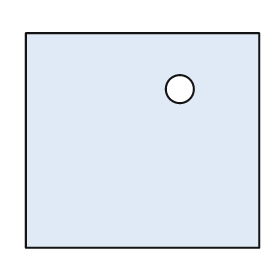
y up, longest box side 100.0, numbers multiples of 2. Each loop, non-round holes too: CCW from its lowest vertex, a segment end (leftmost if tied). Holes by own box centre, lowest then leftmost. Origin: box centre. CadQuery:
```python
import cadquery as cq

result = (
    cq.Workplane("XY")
    .moveTo(-50.0, -46.0)
    .lineTo(50.0, -46.0)
    .lineTo(50.0, 46.0)
    .lineTo(-50.0, 46.0)
    .close()
    .moveTo(16.0, 22.0)
    .circle(6.0)
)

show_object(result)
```